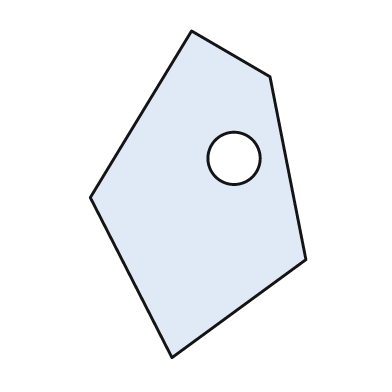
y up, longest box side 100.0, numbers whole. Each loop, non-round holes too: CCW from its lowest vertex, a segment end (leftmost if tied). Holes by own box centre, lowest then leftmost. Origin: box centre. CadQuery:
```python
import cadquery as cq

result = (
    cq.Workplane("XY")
    .moveTo(-8.0, -50.0)
    .lineTo(33.0, -20.0)
    .lineTo(22.0, 36.0)
    .lineTo(-2.0, 50.0)
    .lineTo(-33.0, -1.0)
    .close()
    .moveTo(11.0, 11.0)
    .circle(8.0)
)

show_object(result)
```